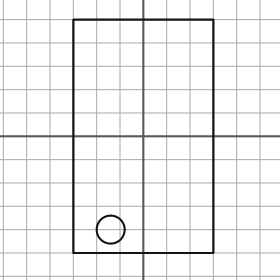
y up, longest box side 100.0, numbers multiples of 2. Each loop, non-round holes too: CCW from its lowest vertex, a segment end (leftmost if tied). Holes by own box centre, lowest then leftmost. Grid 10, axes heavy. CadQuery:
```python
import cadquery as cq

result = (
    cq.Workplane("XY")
    .moveTo(-30.0, -50.0)
    .lineTo(30.0, -50.0)
    .lineTo(30.0, 50.0)
    .lineTo(-30.0, 50.0)
    .close()
    .moveTo(-14.0, -40.0)
    .circle(6.0)
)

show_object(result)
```